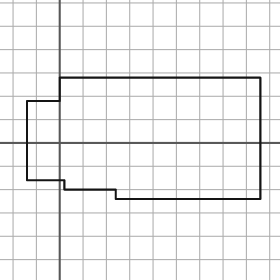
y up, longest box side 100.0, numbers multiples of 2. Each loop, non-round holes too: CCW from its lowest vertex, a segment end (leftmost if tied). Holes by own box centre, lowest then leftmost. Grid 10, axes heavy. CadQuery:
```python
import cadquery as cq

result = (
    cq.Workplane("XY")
    .moveTo(24.0, -24.0)
    .lineTo(86.0, -24.0)
    .lineTo(86.0, 28.0)
    .lineTo(0.0, 28.0)
    .lineTo(0.0, 18.0)
    .lineTo(-14.0, 18.0)
    .lineTo(-14.0, -16.0)
    .lineTo(2.0, -16.0)
    .lineTo(2.0, -20.0)
    .lineTo(24.0, -20.0)
    .close()
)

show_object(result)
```